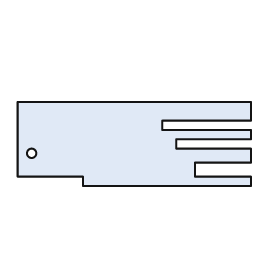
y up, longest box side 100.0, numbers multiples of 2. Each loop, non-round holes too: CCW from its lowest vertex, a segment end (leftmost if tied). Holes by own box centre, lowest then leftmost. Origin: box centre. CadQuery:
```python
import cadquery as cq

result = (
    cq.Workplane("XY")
    .moveTo(-22.0, -18.0)
    .lineTo(50.0, -18.0)
    .lineTo(50.0, -14.0)
    .lineTo(26.0, -14.0)
    .lineTo(26.0, -8.0)
    .lineTo(50.0, -8.0)
    .lineTo(50.0, -2.0)
    .lineTo(18.0, -2.0)
    .lineTo(18.0, 2.0)
    .lineTo(50.0, 2.0)
    .lineTo(50.0, 6.0)
    .lineTo(12.0, 6.0)
    .lineTo(12.0, 10.0)
    .lineTo(50.0, 10.0)
    .lineTo(50.0, 18.0)
    .lineTo(-50.0, 18.0)
    .lineTo(-50.0, -14.0)
    .lineTo(-22.0, -14.0)
    .close()
    .moveTo(-44.0, -4.0)
    .circle(2.0)
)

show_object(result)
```